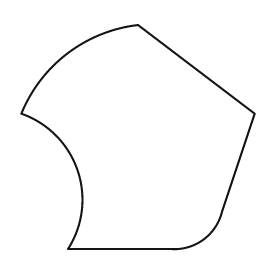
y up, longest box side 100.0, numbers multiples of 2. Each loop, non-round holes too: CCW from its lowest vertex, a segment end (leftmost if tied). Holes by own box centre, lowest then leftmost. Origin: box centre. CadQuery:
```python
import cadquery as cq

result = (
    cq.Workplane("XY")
    .moveTo(-30.0, -48.0)
    .lineTo(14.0, -48.0)
    .threePointArc((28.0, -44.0), (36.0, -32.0))
    .lineTo(50.0, 10.0)
    .lineTo(0.0, 48.0)
    .threePointArc((-30.0, 36.0), (-50.0, 10.0))
    .threePointArc((-26.0, -14.0), (-30.0, -48.0))
    .close()
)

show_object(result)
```